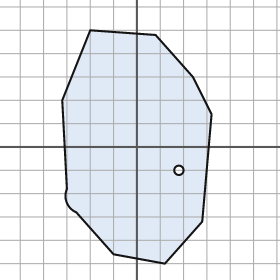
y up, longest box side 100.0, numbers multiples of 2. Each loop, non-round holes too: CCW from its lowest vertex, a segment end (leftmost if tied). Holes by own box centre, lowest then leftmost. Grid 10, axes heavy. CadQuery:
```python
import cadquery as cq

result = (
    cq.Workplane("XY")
    .moveTo(12.0, -50.0)
    .lineTo(28.0, -32.0)
    .lineTo(32.0, 14.0)
    .lineTo(24.0, 30.0)
    .lineTo(8.0, 48.0)
    .lineTo(-20.0, 50.0)
    .lineTo(-32.0, 20.0)
    .lineTo(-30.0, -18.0)
    .threePointArc((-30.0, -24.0), (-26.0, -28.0))
    .lineTo(-10.0, -46.0)
    .close()
    .moveTo(18.0, -10.0)
    .circle(2.0)
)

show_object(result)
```